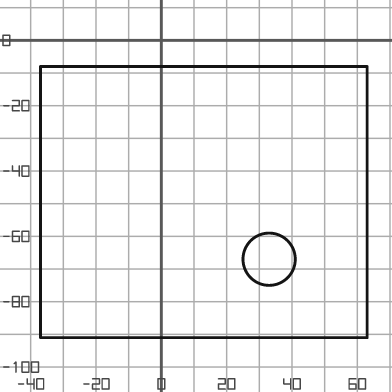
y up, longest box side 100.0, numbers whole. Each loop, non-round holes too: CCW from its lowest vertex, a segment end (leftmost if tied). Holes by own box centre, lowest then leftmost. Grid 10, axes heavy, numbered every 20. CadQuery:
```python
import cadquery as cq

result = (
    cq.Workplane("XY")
    .moveTo(-37.0, -91.0)
    .lineTo(63.0, -91.0)
    .lineTo(63.0, -8.0)
    .lineTo(-37.0, -8.0)
    .close()
    .moveTo(33.0, -67.0)
    .circle(8.0)
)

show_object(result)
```